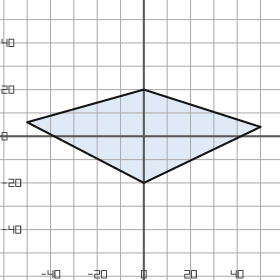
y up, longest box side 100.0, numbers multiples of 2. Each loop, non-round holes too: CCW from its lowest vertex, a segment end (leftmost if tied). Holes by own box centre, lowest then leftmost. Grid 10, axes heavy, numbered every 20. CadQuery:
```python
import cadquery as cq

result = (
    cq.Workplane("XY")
    .moveTo(0.0, -20.0)
    .lineTo(50.0, 4.0)
    .lineTo(0.0, 20.0)
    .lineTo(-50.0, 6.0)
    .close()
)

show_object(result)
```